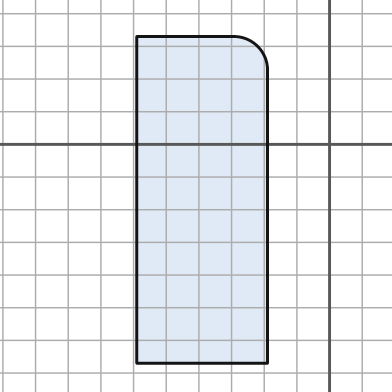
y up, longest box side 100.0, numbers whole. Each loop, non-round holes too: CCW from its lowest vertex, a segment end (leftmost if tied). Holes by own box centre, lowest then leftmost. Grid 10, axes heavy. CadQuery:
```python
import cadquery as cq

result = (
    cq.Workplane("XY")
    .moveTo(-59.0, -67.0)
    .lineTo(-19.0, -67.0)
    .lineTo(-19.0, 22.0)
    .threePointArc((-22.0, 30.0), (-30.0, 33.0))
    .lineTo(-59.0, 33.0)
    .close()
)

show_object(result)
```